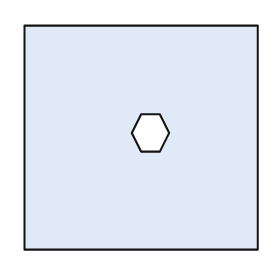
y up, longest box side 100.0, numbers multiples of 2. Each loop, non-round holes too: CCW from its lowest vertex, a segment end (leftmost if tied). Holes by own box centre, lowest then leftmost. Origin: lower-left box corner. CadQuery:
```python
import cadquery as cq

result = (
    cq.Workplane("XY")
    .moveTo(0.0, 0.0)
    .lineTo(100.0, 0.0)
    .lineTo(100.0, 96.0)
    .lineTo(0.0, 96.0)
    .close()
    .moveTo(50.0, 42.0)
    .lineTo(58.0, 42.0)
    .lineTo(62.0, 50.0)
    .lineTo(58.0, 58.0)
    .lineTo(50.0, 58.0)
    .lineTo(46.0, 50.0)
    .close()
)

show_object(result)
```